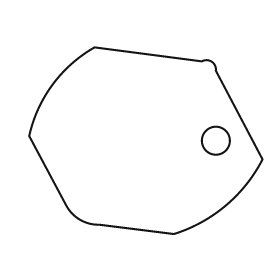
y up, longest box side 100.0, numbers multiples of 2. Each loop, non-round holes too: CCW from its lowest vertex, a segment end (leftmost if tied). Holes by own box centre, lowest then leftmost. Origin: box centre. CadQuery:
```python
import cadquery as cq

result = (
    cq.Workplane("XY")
    .moveTo(12.0, -40.0)
    .threePointArc((34.0, -28.0), (50.0, -8.0))
    .lineTo(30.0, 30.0)
    .threePointArc((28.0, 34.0), (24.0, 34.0))
    .lineTo(-22.0, 40.0)
    .threePointArc((-40.0, 24.0), (-50.0, 2.0))
    .lineTo(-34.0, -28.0)
    .threePointArc((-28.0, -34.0), (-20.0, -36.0))
    .close()
    .moveTo(30.0, 0.0)
    .circle(6.0)
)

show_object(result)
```